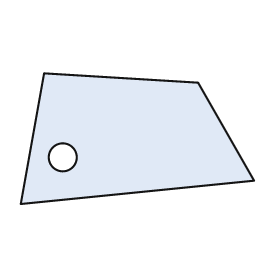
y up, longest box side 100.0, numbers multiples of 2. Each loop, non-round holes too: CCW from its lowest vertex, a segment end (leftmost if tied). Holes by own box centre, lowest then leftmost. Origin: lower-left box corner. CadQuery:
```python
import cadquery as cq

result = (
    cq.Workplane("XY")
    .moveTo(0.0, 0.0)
    .lineTo(100.0, 10.0)
    .lineTo(76.0, 52.0)
    .lineTo(10.0, 56.0)
    .close()
    .moveTo(18.0, 20.0)
    .circle(6.0)
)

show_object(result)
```